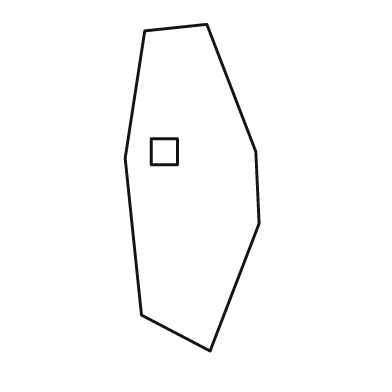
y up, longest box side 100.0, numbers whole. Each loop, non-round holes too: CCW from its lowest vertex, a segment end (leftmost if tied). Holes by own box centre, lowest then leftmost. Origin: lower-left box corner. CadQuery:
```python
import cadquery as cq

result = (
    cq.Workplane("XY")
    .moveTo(26.0, 0.0)
    .lineTo(41.0, 39.0)
    .lineTo(40.0, 61.0)
    .lineTo(25.0, 100.0)
    .lineTo(6.0, 98.0)
    .lineTo(0.0, 59.0)
    .lineTo(5.0, 11.0)
    .close()
    .moveTo(8.0, 57.0)
    .lineTo(16.0, 57.0)
    .lineTo(16.0, 65.0)
    .lineTo(8.0, 65.0)
    .close()
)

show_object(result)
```